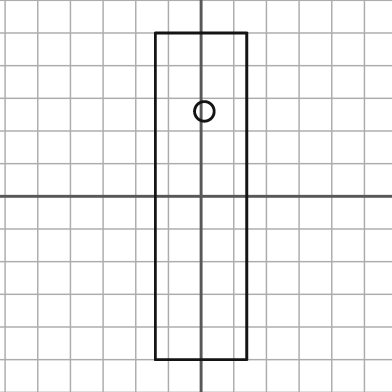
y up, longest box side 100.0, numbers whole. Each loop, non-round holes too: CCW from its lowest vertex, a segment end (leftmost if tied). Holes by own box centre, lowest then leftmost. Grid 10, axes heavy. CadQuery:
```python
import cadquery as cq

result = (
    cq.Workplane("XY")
    .moveTo(-14.0, -50.0)
    .lineTo(14.0, -50.0)
    .lineTo(14.0, 50.0)
    .lineTo(-14.0, 50.0)
    .close()
    .moveTo(1.0, 26.0)
    .circle(3.0)
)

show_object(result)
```